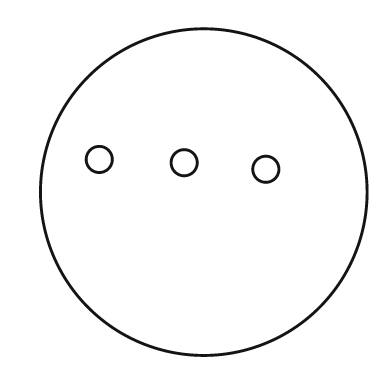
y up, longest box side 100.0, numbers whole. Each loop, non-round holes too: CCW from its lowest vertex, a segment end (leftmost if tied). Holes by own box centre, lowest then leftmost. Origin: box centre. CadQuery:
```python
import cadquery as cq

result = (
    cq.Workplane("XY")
    .moveTo(0.0, 0.0)
    .circle(50.0)
    .moveTo(19.0, 7.0)
    .circle(4.0)
    .moveTo(-6.0, 9.0)
    .circle(4.0)
    .moveTo(-32.0, 10.0)
    .circle(4.0)
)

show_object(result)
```